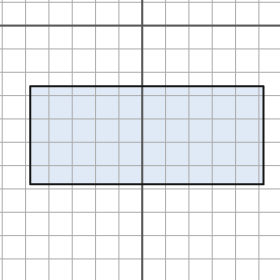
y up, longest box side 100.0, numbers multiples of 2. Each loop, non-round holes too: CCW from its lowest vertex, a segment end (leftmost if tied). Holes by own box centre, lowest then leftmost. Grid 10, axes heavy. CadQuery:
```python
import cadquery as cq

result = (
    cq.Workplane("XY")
    .moveTo(-48.0, -68.0)
    .lineTo(52.0, -68.0)
    .lineTo(52.0, -26.0)
    .lineTo(-48.0, -26.0)
    .close()
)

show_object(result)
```